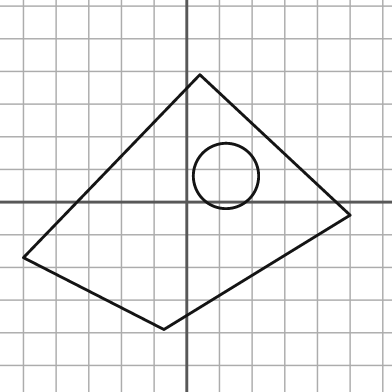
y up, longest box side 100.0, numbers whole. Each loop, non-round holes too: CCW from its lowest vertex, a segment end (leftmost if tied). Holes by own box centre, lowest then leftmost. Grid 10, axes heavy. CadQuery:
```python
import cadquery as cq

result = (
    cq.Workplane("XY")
    .moveTo(-7.0, -39.0)
    .lineTo(50.0, -4.0)
    .lineTo(4.0, 39.0)
    .lineTo(-50.0, -17.0)
    .close()
    .moveTo(12.0, 8.0)
    .circle(10.0)
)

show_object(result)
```